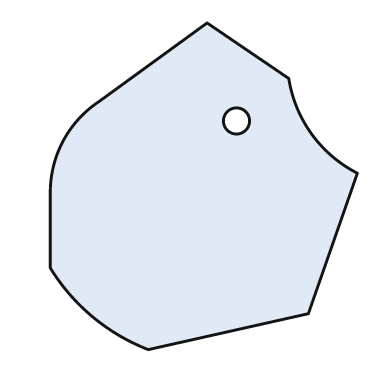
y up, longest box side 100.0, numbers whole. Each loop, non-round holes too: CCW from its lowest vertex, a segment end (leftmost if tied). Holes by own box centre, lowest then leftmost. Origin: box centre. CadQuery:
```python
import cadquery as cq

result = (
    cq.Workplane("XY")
    .moveTo(-17.0, -50.0)
    .lineTo(32.0, -39.0)
    .lineTo(47.0, 4.0)
    .threePointArc((33.0, 16.0), (26.0, 33.0))
    .lineTo(1.0, 50.0)
    .lineTo(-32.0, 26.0)
    .threePointArc((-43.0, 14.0), (-47.0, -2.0))
    .lineTo(-47.0, -25.0)
    .threePointArc((-34.0, -40.0), (-17.0, -50.0))
    .close()
    .moveTo(10.0, 20.0)
    .circle(4.0)
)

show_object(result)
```